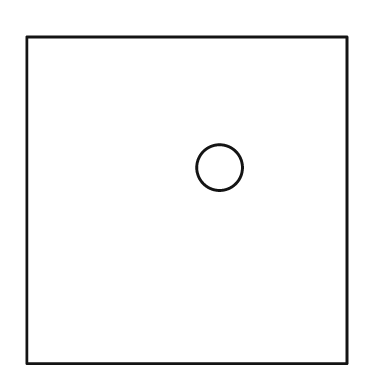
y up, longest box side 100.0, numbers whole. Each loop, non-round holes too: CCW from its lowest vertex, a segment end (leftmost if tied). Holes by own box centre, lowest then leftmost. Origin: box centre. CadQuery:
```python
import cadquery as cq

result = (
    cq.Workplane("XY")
    .moveTo(-49.0, -50.0)
    .lineTo(49.0, -50.0)
    .lineTo(49.0, 50.0)
    .lineTo(-49.0, 50.0)
    .close()
    .moveTo(10.0, 10.0)
    .circle(7.0)
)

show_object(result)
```